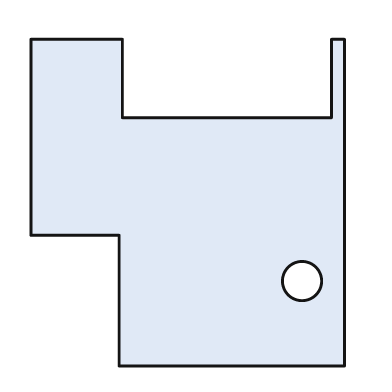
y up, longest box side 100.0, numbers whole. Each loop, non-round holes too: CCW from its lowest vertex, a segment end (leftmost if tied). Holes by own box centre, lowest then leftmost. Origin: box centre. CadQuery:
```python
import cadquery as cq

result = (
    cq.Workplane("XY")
    .moveTo(-21.0, -50.0)
    .lineTo(48.0, -50.0)
    .lineTo(48.0, 50.0)
    .lineTo(44.0, 50.0)
    .lineTo(44.0, 26.0)
    .lineTo(-20.0, 26.0)
    .lineTo(-20.0, 50.0)
    .lineTo(-48.0, 50.0)
    .lineTo(-48.0, -10.0)
    .lineTo(-21.0, -10.0)
    .close()
    .moveTo(35.0, -24.0)
    .circle(6.0)
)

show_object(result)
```